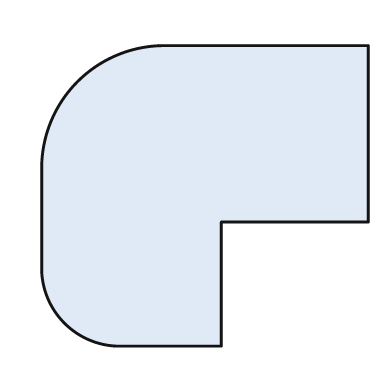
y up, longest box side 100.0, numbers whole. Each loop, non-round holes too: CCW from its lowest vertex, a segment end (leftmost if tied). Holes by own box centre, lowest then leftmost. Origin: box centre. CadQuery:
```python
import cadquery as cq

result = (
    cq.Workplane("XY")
    .moveTo(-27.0, -46.0)
    .lineTo(5.0, -46.0)
    .lineTo(5.0, -8.0)
    .lineTo(50.0, -8.0)
    .lineTo(50.0, 46.0)
    .lineTo(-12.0, 46.0)
    .threePointArc((-39.0, 35.0), (-50.0, 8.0))
    .lineTo(-50.0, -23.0)
    .threePointArc((-43.0, -39.0), (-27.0, -46.0))
    .close()
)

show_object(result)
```